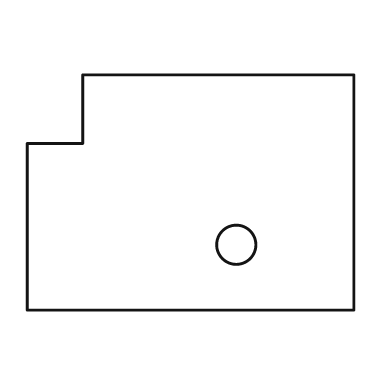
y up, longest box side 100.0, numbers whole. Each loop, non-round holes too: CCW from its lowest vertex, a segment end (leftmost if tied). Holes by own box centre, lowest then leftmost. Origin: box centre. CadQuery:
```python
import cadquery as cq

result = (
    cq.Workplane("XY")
    .moveTo(-50.0, -36.0)
    .lineTo(50.0, -36.0)
    .lineTo(50.0, 36.0)
    .lineTo(-33.0, 36.0)
    .lineTo(-33.0, 15.0)
    .lineTo(-50.0, 15.0)
    .close()
    .moveTo(14.0, -16.0)
    .circle(6.0)
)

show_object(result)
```